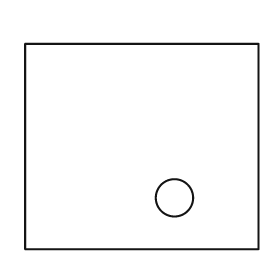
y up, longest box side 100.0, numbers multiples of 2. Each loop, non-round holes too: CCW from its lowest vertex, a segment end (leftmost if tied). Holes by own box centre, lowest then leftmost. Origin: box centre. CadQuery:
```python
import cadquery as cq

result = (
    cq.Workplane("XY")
    .moveTo(-50.0, -44.0)
    .lineTo(50.0, -44.0)
    .lineTo(50.0, 44.0)
    .lineTo(-50.0, 44.0)
    .close()
    .moveTo(14.0, -22.0)
    .circle(8.0)
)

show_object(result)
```